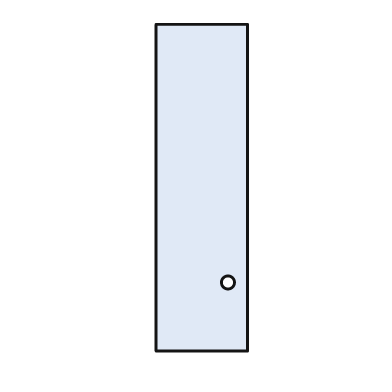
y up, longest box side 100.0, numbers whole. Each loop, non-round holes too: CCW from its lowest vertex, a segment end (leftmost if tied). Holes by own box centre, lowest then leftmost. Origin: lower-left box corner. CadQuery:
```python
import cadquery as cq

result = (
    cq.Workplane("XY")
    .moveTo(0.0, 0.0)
    .lineTo(28.0, 0.0)
    .lineTo(28.0, 100.0)
    .lineTo(0.0, 100.0)
    .close()
    .moveTo(22.0, 21.0)
    .circle(2.0)
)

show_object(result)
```